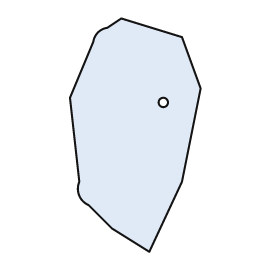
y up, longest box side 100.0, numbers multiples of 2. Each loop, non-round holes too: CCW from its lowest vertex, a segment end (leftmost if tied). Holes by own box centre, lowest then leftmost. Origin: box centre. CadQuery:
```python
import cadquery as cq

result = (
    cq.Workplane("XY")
    .moveTo(6.0, -50.0)
    .lineTo(20.0, -20.0)
    .lineTo(28.0, 20.0)
    .lineTo(20.0, 42.0)
    .lineTo(-6.0, 50.0)
    .lineTo(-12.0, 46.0)
    .threePointArc((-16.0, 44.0), (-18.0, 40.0))
    .lineTo(-28.0, 16.0)
    .lineTo(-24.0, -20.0)
    .threePointArc((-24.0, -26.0), (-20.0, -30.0))
    .lineTo(-10.0, -40.0)
    .close()
    .moveTo(12.0, 14.0)
    .circle(2.0)
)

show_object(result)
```